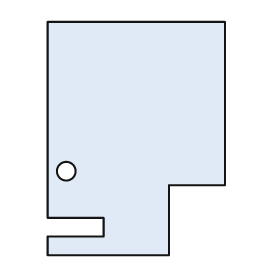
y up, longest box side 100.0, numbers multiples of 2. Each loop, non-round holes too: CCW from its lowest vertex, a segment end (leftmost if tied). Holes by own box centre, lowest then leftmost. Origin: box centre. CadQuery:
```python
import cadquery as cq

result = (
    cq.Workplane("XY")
    .moveTo(-38.0, -50.0)
    .lineTo(14.0, -50.0)
    .lineTo(14.0, -20.0)
    .lineTo(38.0, -20.0)
    .lineTo(38.0, 50.0)
    .lineTo(-38.0, 50.0)
    .lineTo(-38.0, -34.0)
    .lineTo(-14.0, -34.0)
    .lineTo(-14.0, -42.0)
    .lineTo(-38.0, -42.0)
    .close()
    .moveTo(-30.0, -14.0)
    .circle(4.0)
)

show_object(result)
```